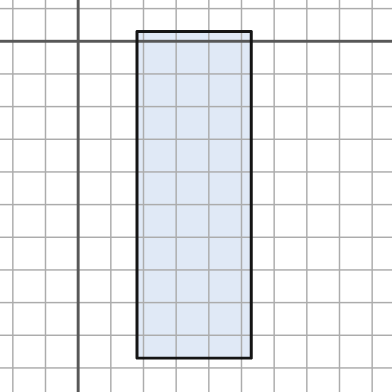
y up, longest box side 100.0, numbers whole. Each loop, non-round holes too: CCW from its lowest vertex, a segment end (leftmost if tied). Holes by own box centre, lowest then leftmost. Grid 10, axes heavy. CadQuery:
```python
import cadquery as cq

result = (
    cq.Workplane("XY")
    .moveTo(18.0, -97.0)
    .lineTo(53.0, -97.0)
    .lineTo(53.0, 3.0)
    .lineTo(18.0, 3.0)
    .close()
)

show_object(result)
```